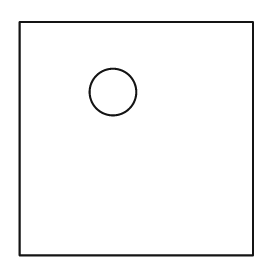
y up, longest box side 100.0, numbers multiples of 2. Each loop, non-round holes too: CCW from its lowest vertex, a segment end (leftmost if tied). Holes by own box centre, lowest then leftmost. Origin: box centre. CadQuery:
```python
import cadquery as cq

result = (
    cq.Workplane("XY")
    .moveTo(-50.0, -50.0)
    .lineTo(50.0, -50.0)
    .lineTo(50.0, 50.0)
    .lineTo(-50.0, 50.0)
    .close()
    .moveTo(-10.0, 20.0)
    .circle(10.0)
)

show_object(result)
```